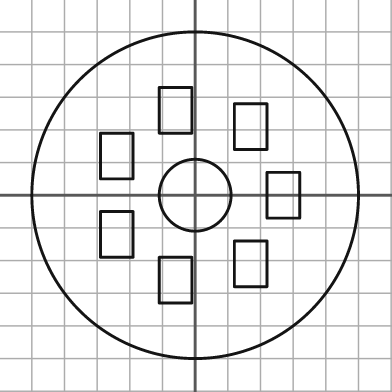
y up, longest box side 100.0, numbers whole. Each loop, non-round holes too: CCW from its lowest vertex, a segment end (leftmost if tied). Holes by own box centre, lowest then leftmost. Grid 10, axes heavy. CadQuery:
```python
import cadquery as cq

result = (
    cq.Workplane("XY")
    .moveTo(0.0, 0.0)
    .circle(50.0)
    .moveTo(-11.0, -33.0)
    .lineTo(-1.0, -33.0)
    .lineTo(-1.0, -19.0)
    .lineTo(-11.0, -19.0)
    .close()
    .moveTo(12.0, -28.0)
    .lineTo(22.0, -28.0)
    .lineTo(22.0, -14.0)
    .lineTo(12.0, -14.0)
    .close()
    .moveTo(-29.0, -19.0)
    .lineTo(-19.0, -19.0)
    .lineTo(-19.0, -5.0)
    .lineTo(-29.0, -5.0)
    .close()
    .moveTo(0.0, 0.0)
    .circle(11.0)
    .moveTo(22.0, -7.0)
    .lineTo(32.0, -7.0)
    .lineTo(32.0, 7.0)
    .lineTo(22.0, 7.0)
    .close()
    .moveTo(-29.0, 5.0)
    .lineTo(-19.0, 5.0)
    .lineTo(-19.0, 19.0)
    .lineTo(-29.0, 19.0)
    .close()
    .moveTo(12.0, 14.0)
    .lineTo(22.0, 14.0)
    .lineTo(22.0, 28.0)
    .lineTo(12.0, 28.0)
    .close()
    .moveTo(-11.0, 19.0)
    .lineTo(-1.0, 19.0)
    .lineTo(-1.0, 33.0)
    .lineTo(-11.0, 33.0)
    .close()
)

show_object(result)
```